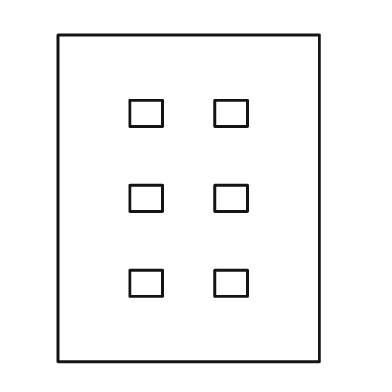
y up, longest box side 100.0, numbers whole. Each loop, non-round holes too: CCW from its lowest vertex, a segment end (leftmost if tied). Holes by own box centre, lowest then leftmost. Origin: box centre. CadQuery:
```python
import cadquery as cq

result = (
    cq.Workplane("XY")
    .moveTo(-40.0, -50.0)
    .lineTo(40.0, -50.0)
    .lineTo(40.0, 50.0)
    .lineTo(-40.0, 50.0)
    .close()
    .moveTo(-18.0, -30.0)
    .lineTo(-8.0, -30.0)
    .lineTo(-8.0, -22.0)
    .lineTo(-18.0, -22.0)
    .close()
    .moveTo(8.0, -30.0)
    .lineTo(18.0, -30.0)
    .lineTo(18.0, -22.0)
    .lineTo(8.0, -22.0)
    .close()
    .moveTo(-18.0, -4.0)
    .lineTo(-8.0, -4.0)
    .lineTo(-8.0, 4.0)
    .lineTo(-18.0, 4.0)
    .close()
    .moveTo(8.0, -4.0)
    .lineTo(18.0, -4.0)
    .lineTo(18.0, 4.0)
    .lineTo(8.0, 4.0)
    .close()
    .moveTo(-18.0, 22.0)
    .lineTo(-8.0, 22.0)
    .lineTo(-8.0, 30.0)
    .lineTo(-18.0, 30.0)
    .close()
    .moveTo(8.0, 22.0)
    .lineTo(18.0, 22.0)
    .lineTo(18.0, 30.0)
    .lineTo(8.0, 30.0)
    .close()
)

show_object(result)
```